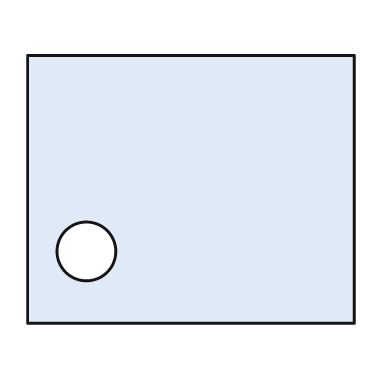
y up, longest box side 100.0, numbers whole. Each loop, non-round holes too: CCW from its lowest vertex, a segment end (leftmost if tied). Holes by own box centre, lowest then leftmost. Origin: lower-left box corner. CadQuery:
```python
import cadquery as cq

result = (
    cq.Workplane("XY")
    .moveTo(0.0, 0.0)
    .lineTo(100.0, 0.0)
    .lineTo(100.0, 82.0)
    .lineTo(0.0, 82.0)
    .close()
    .moveTo(18.0, 22.0)
    .circle(9.0)
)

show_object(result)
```